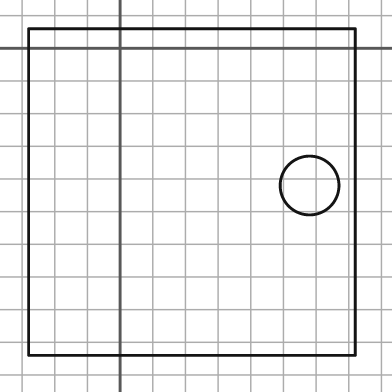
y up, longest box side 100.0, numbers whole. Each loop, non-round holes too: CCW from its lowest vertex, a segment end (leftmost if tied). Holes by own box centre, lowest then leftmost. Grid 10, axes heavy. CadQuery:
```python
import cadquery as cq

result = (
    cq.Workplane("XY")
    .moveTo(-28.0, -94.0)
    .lineTo(72.0, -94.0)
    .lineTo(72.0, 6.0)
    .lineTo(-28.0, 6.0)
    .close()
    .moveTo(58.0, -42.0)
    .circle(9.0)
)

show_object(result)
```